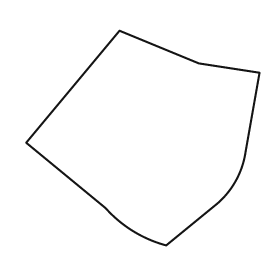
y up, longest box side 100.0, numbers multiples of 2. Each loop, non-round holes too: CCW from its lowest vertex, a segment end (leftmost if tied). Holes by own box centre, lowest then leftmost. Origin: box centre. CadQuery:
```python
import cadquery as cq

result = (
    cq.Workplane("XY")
    .moveTo(10.0, -46.0)
    .lineTo(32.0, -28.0)
    .threePointArc((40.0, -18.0), (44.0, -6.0))
    .lineTo(50.0, 28.0)
    .lineTo(24.0, 32.0)
    .lineTo(-10.0, 46.0)
    .lineTo(-50.0, -2.0)
    .lineTo(-16.0, -30.0)
    .threePointArc((-4.0, -40.0), (10.0, -46.0))
    .close()
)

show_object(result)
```